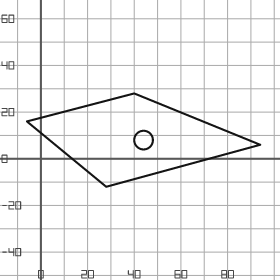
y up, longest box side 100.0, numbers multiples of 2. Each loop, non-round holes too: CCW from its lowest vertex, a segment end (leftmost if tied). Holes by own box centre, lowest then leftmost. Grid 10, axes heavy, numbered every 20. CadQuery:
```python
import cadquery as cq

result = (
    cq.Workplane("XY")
    .moveTo(28.0, -12.0)
    .lineTo(94.0, 6.0)
    .lineTo(40.0, 28.0)
    .lineTo(-6.0, 16.0)
    .close()
    .moveTo(44.0, 8.0)
    .circle(4.0)
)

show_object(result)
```